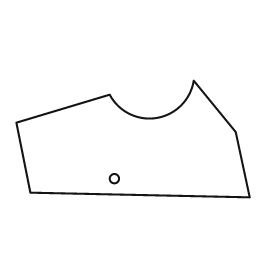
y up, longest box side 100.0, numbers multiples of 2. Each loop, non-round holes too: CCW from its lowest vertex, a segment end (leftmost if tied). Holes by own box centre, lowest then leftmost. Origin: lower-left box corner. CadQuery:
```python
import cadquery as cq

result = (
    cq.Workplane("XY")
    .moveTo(100.0, 0.0)
    .lineTo(94.0, 28.0)
    .lineTo(76.0, 50.0)
    .threePointArc((60.0, 34.0), (40.0, 44.0))
    .lineTo(0.0, 32.0)
    .lineTo(6.0, 2.0)
    .close()
    .moveTo(42.0, 8.0)
    .circle(2.0)
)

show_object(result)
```